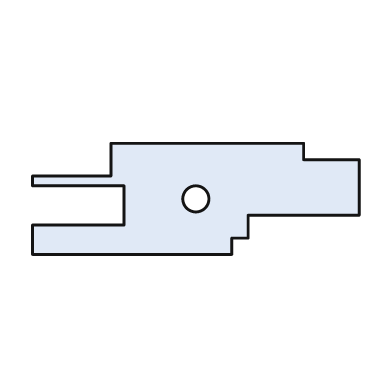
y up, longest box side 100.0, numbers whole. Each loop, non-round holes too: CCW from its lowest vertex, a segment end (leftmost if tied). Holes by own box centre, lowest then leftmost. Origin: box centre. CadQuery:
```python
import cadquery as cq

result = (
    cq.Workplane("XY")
    .moveTo(-50.0, -17.0)
    .lineTo(11.0, -17.0)
    .lineTo(11.0, -12.0)
    .lineTo(16.0, -12.0)
    .lineTo(16.0, -5.0)
    .lineTo(50.0, -5.0)
    .lineTo(50.0, 12.0)
    .lineTo(33.0, 12.0)
    .lineTo(33.0, 17.0)
    .lineTo(-26.0, 17.0)
    .lineTo(-26.0, 7.0)
    .lineTo(-50.0, 7.0)
    .lineTo(-50.0, 4.0)
    .lineTo(-22.0, 4.0)
    .lineTo(-22.0, -8.0)
    .lineTo(-50.0, -8.0)
    .close()
    .moveTo(0.0, 0.0)
    .circle(4.0)
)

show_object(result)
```